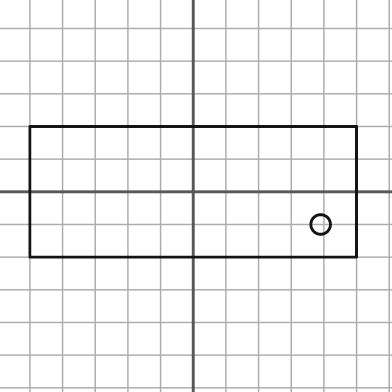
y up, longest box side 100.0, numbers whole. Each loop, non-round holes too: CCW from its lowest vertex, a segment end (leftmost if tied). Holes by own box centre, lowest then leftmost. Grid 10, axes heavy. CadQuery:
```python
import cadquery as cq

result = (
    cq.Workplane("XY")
    .moveTo(-50.0, -20.0)
    .lineTo(50.0, -20.0)
    .lineTo(50.0, 20.0)
    .lineTo(-50.0, 20.0)
    .close()
    .moveTo(39.0, -10.0)
    .circle(3.0)
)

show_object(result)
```